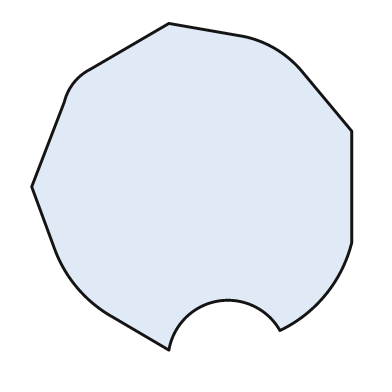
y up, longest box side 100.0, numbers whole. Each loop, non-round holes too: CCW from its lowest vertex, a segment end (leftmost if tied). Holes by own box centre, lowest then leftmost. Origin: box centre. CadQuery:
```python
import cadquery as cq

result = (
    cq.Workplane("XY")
    .moveTo(-7.0, -50.0)
    .threePointArc((8.0, -35.0), (27.0, -44.0))
    .threePointArc((41.0, -33.0), (49.0, -17.0))
    .lineTo(49.0, 17.0)
    .lineTo(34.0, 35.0)
    .threePointArc((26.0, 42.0), (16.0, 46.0))
    .lineTo(-7.0, 50.0)
    .lineTo(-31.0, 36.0)
    .threePointArc((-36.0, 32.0), (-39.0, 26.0))
    .lineTo(-49.0, 0.0)
    .lineTo(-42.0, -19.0)
    .threePointArc((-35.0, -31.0), (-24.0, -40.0))
    .close()
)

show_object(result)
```